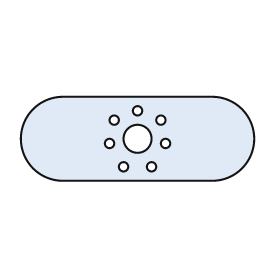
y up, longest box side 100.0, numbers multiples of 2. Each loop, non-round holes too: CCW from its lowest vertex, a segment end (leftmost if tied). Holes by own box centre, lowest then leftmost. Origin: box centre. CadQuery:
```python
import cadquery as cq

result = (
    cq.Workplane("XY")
    .moveTo(-32.0, -18.0)
    .lineTo(32.0, -18.0)
    .threePointArc((50.0, 0.0), (32.0, 18.0))
    .lineTo(-32.0, 18.0)
    .threePointArc((-50.0, 0.0), (-32.0, -18.0))
    .close()
    .moveTo(-6.0, -12.0)
    .circle(2.0)
    .moveTo(6.0, -12.0)
    .circle(2.0)
    .moveTo(-12.0, -2.0)
    .circle(2.0)
    .moveTo(12.0, -2.0)
    .circle(2.0)
    .moveTo(0.0, 0.0)
    .circle(6.0)
    .moveTo(-10.0, 8.0)
    .circle(2.0)
    .moveTo(10.0, 8.0)
    .circle(2.0)
    .moveTo(0.0, 12.0)
    .circle(2.0)
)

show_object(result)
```